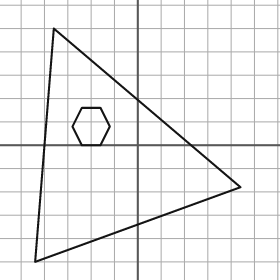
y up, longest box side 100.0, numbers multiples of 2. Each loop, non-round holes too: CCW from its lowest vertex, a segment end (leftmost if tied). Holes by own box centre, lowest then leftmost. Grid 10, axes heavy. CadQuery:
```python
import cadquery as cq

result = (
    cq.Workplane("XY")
    .moveTo(-44.0, -50.0)
    .lineTo(44.0, -18.0)
    .lineTo(-36.0, 50.0)
    .close()
    .moveTo(-24.0, 0.0)
    .lineTo(-16.0, 0.0)
    .lineTo(-12.0, 8.0)
    .lineTo(-16.0, 16.0)
    .lineTo(-24.0, 16.0)
    .lineTo(-28.0, 8.0)
    .close()
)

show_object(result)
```